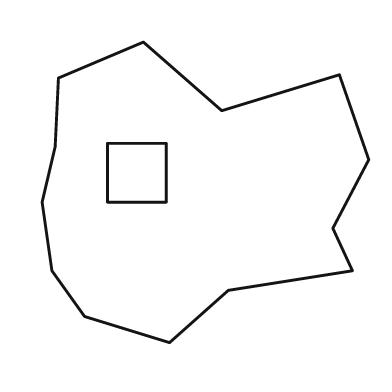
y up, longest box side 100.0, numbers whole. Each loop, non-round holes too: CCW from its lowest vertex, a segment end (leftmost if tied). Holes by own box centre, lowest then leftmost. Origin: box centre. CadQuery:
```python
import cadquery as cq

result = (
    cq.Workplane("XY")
    .moveTo(-11.0, -46.0)
    .lineTo(7.0, -30.0)
    .lineTo(45.0, -24.0)
    .lineTo(39.0, -11.0)
    .lineTo(50.0, 10.0)
    .lineTo(41.0, 36.0)
    .lineTo(5.0, 25.0)
    .lineTo(-19.0, 46.0)
    .lineTo(-45.0, 35.0)
    .lineTo(-46.0, 14.0)
    .lineTo(-50.0, -3.0)
    .lineTo(-47.0, -24.0)
    .lineTo(-37.0, -38.0)
    .close()
    .moveTo(-30.0, -3.0)
    .lineTo(-12.0, -3.0)
    .lineTo(-12.0, 15.0)
    .lineTo(-30.0, 15.0)
    .close()
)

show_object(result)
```